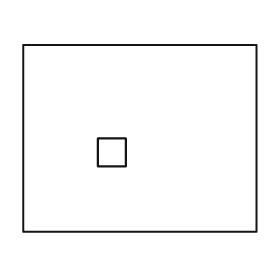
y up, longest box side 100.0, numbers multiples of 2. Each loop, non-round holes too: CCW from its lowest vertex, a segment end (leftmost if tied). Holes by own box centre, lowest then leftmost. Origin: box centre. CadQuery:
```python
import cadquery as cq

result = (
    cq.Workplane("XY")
    .moveTo(-50.0, -40.0)
    .lineTo(50.0, -40.0)
    .lineTo(50.0, 40.0)
    .lineTo(-50.0, 40.0)
    .close()
    .moveTo(-18.0, -12.0)
    .lineTo(-6.0, -12.0)
    .lineTo(-6.0, 0.0)
    .lineTo(-18.0, 0.0)
    .close()
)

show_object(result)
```